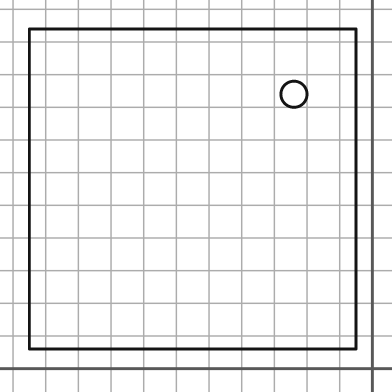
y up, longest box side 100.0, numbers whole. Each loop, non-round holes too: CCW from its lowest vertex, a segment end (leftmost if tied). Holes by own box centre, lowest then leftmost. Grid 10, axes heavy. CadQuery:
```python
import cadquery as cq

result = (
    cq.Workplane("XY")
    .moveTo(-105.0, 6.0)
    .lineTo(-5.0, 6.0)
    .lineTo(-5.0, 104.0)
    .lineTo(-105.0, 104.0)
    .close()
    .moveTo(-24.0, 84.0)
    .circle(4.0)
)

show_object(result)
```